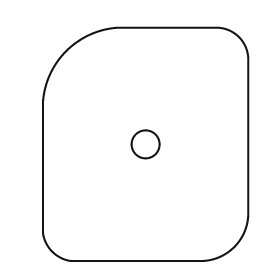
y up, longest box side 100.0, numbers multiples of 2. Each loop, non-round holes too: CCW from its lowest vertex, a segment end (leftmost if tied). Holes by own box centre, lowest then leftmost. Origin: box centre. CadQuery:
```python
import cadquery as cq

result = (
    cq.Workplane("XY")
    .moveTo(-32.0, -50.0)
    .lineTo(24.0, -50.0)
    .threePointArc((38.0, -44.0), (44.0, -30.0))
    .lineTo(44.0, 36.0)
    .threePointArc((40.0, 46.0), (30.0, 50.0))
    .lineTo(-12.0, 50.0)
    .threePointArc((-34.0, 40.0), (-44.0, 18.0))
    .lineTo(-44.0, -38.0)
    .threePointArc((-40.0, -46.0), (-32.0, -50.0))
    .close()
    .moveTo(0.0, 0.0)
    .circle(6.0)
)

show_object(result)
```